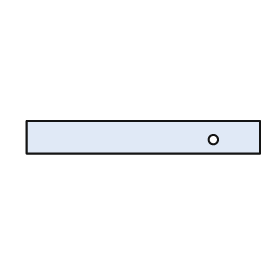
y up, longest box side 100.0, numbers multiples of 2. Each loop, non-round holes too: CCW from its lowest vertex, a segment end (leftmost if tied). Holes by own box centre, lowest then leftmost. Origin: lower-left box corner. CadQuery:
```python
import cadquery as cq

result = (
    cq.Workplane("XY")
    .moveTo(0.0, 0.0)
    .lineTo(100.0, 0.0)
    .lineTo(100.0, 14.0)
    .lineTo(0.0, 14.0)
    .close()
    .moveTo(80.0, 6.0)
    .circle(2.0)
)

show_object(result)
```